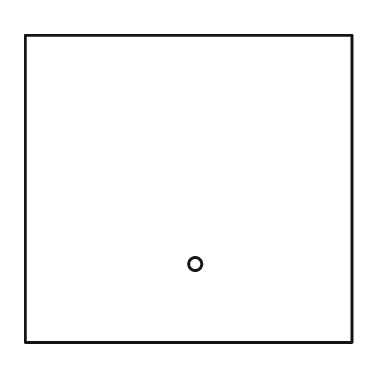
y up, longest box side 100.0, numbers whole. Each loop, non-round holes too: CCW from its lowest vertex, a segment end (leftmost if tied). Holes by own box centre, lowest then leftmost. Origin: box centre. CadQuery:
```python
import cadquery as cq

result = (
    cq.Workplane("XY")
    .moveTo(-50.0, -47.0)
    .lineTo(50.0, -47.0)
    .lineTo(50.0, 47.0)
    .lineTo(-50.0, 47.0)
    .close()
    .moveTo(2.0, -23.0)
    .circle(2.0)
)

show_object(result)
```